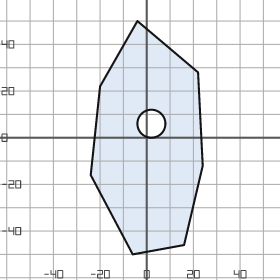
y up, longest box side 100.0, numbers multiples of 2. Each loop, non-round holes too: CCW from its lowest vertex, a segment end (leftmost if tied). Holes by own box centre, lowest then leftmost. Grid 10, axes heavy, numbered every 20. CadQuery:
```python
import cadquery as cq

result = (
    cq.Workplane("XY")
    .moveTo(-6.0, -50.0)
    .lineTo(16.0, -46.0)
    .lineTo(24.0, -12.0)
    .lineTo(22.0, 28.0)
    .lineTo(-4.0, 50.0)
    .lineTo(-20.0, 22.0)
    .lineTo(-24.0, -16.0)
    .close()
    .moveTo(2.0, 6.0)
    .circle(6.0)
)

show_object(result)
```